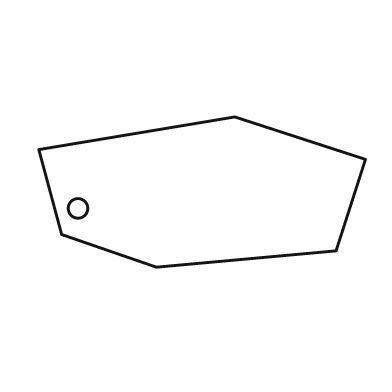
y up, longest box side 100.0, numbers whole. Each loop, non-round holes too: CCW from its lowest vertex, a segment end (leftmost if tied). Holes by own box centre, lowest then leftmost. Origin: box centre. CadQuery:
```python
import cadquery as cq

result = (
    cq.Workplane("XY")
    .moveTo(-14.0, -23.0)
    .lineTo(41.0, -18.0)
    .lineTo(50.0, 10.0)
    .lineTo(10.0, 23.0)
    .lineTo(-50.0, 13.0)
    .lineTo(-43.0, -13.0)
    .close()
    .moveTo(-38.0, -5.0)
    .circle(3.0)
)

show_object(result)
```